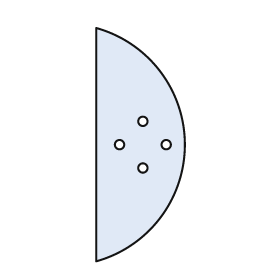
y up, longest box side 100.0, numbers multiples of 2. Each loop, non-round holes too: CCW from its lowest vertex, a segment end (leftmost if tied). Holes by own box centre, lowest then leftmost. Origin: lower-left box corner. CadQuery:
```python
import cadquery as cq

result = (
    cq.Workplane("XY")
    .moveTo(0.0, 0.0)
    .threePointArc((38.0, 50.0), (0.0, 100.0))
    .close()
    .moveTo(20.0, 40.0)
    .circle(2.0)
    .moveTo(10.0, 50.0)
    .circle(2.0)
    .moveTo(30.0, 50.0)
    .circle(2.0)
    .moveTo(20.0, 60.0)
    .circle(2.0)
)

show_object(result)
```